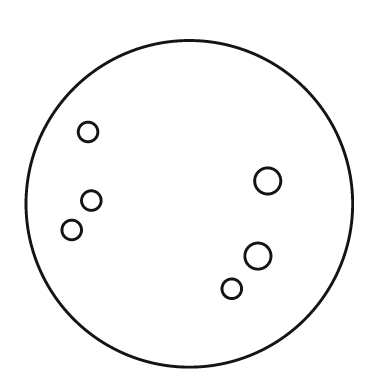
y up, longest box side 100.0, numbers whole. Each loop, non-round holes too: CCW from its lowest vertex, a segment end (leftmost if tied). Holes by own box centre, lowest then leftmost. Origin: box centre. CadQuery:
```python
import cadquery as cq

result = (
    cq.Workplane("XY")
    .moveTo(0.0, 0.0)
    .circle(50.0)
    .moveTo(13.0, -26.0)
    .circle(3.0)
    .moveTo(21.0, -16.0)
    .circle(4.0)
    .moveTo(-36.0, -8.0)
    .circle(3.0)
    .moveTo(-30.0, 1.0)
    .circle(3.0)
    .moveTo(24.0, 7.0)
    .circle(4.0)
    .moveTo(-31.0, 22.0)
    .circle(3.0)
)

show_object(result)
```